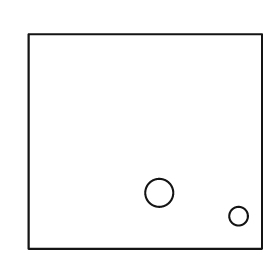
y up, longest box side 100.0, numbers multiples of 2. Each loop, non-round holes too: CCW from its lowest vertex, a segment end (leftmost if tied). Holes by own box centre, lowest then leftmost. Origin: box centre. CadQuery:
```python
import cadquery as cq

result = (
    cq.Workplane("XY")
    .moveTo(-50.0, -46.0)
    .lineTo(50.0, -46.0)
    .lineTo(50.0, 46.0)
    .lineTo(-50.0, 46.0)
    .close()
    .moveTo(40.0, -32.0)
    .circle(4.0)
    .moveTo(6.0, -22.0)
    .circle(6.0)
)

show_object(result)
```